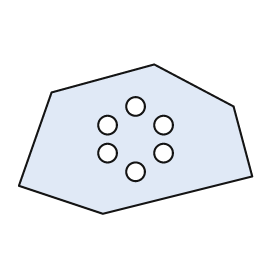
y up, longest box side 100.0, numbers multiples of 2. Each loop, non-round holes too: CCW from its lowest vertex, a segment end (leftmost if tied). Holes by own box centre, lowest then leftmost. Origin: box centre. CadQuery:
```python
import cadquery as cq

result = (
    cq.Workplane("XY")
    .moveTo(-14.0, -32.0)
    .lineTo(50.0, -16.0)
    .lineTo(42.0, 14.0)
    .lineTo(8.0, 32.0)
    .lineTo(-36.0, 20.0)
    .lineTo(-50.0, -20.0)
    .close()
    .moveTo(0.0, -14.0)
    .circle(4.0)
    .moveTo(-12.0, -6.0)
    .circle(4.0)
    .moveTo(12.0, -6.0)
    .circle(4.0)
    .moveTo(-12.0, 6.0)
    .circle(4.0)
    .moveTo(12.0, 6.0)
    .circle(4.0)
    .moveTo(0.0, 14.0)
    .circle(4.0)
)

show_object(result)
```